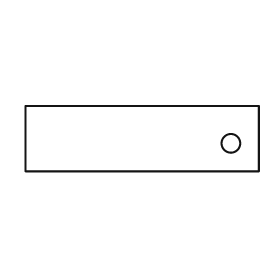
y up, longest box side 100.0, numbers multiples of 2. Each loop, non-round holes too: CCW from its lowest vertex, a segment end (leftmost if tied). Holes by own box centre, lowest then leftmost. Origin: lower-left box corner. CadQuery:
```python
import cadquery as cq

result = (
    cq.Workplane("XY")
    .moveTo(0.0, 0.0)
    .lineTo(100.0, 0.0)
    .lineTo(100.0, 28.0)
    .lineTo(0.0, 28.0)
    .close()
    .moveTo(88.0, 12.0)
    .circle(4.0)
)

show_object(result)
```